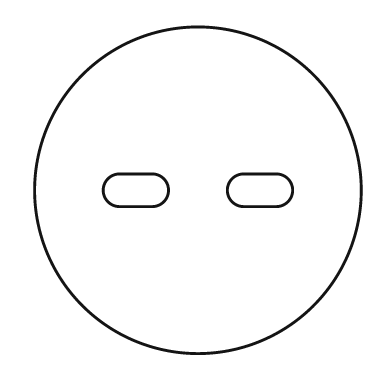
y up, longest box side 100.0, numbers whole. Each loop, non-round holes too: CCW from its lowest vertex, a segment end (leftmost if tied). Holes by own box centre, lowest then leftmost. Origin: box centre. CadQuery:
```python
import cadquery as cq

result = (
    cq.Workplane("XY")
    .moveTo(0.0, 0.0)
    .circle(50.0)
    .moveTo(-24.0, -5.0)
    .lineTo(-14.0, -5.0)
    .threePointArc((-9.0, 0.0), (-14.0, 5.0))
    .lineTo(-24.0, 5.0)
    .threePointArc((-29.0, 0.0), (-24.0, -5.0))
    .close()
    .moveTo(14.0, -5.0)
    .lineTo(24.0, -5.0)
    .threePointArc((29.0, 0.0), (24.0, 5.0))
    .lineTo(14.0, 5.0)
    .threePointArc((9.0, 0.0), (14.0, -5.0))
    .close()
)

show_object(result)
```